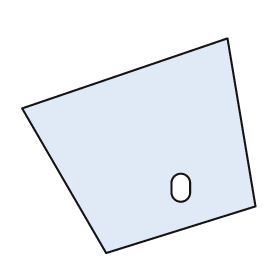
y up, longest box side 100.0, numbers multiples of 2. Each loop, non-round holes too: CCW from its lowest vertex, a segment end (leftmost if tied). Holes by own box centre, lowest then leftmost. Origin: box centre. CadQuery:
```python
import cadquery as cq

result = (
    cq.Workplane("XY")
    .moveTo(-14.0, -46.0)
    .lineTo(50.0, -26.0)
    .lineTo(38.0, 46.0)
    .lineTo(-50.0, 16.0)
    .close()
    .moveTo(14.0, -20.0)
    .threePointArc((18.0, -24.0), (22.0, -20.0))
    .lineTo(22.0, -16.0)
    .threePointArc((18.0, -12.0), (14.0, -16.0))
    .close()
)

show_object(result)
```